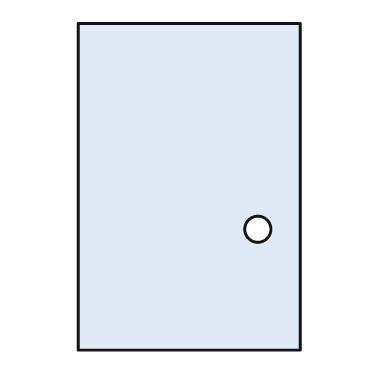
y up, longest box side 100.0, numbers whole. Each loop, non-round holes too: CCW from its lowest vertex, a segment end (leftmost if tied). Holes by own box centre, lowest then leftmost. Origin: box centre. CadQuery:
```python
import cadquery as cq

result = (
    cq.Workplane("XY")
    .moveTo(-34.0, -50.0)
    .lineTo(34.0, -50.0)
    .lineTo(34.0, 50.0)
    .lineTo(-34.0, 50.0)
    .close()
    .moveTo(21.0, -13.0)
    .circle(4.0)
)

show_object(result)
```